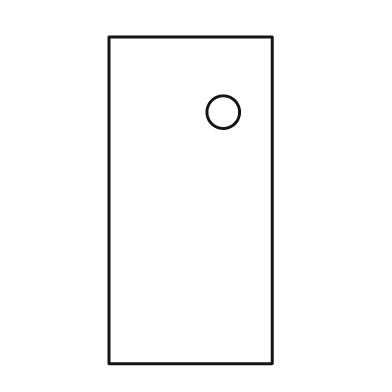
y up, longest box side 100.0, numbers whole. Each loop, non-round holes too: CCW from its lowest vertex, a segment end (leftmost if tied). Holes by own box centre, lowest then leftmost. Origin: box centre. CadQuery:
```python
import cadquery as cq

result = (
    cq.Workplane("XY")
    .moveTo(-25.0, -50.0)
    .lineTo(25.0, -50.0)
    .lineTo(25.0, 50.0)
    .lineTo(-25.0, 50.0)
    .close()
    .moveTo(10.0, 27.0)
    .circle(5.0)
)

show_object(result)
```